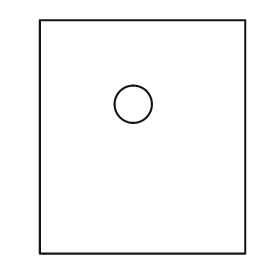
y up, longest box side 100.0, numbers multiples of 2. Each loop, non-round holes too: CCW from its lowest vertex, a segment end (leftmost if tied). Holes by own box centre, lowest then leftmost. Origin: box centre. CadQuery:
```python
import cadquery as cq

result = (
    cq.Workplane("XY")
    .moveTo(-44.0, -50.0)
    .lineTo(44.0, -50.0)
    .lineTo(44.0, 50.0)
    .lineTo(-44.0, 50.0)
    .close()
    .moveTo(-4.0, 14.0)
    .circle(8.0)
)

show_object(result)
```